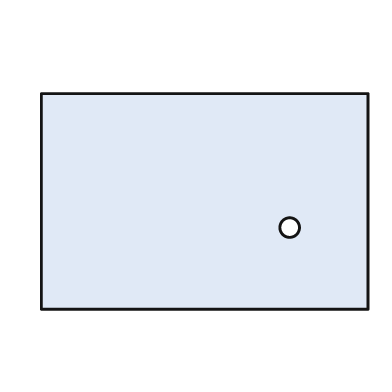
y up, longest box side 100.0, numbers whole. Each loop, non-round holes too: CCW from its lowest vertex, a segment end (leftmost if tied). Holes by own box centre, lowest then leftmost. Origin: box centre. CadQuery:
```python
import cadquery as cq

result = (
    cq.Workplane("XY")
    .moveTo(-50.0, -33.0)
    .lineTo(50.0, -33.0)
    .lineTo(50.0, 33.0)
    .lineTo(-50.0, 33.0)
    .close()
    .moveTo(26.0, -8.0)
    .circle(3.0)
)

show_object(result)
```